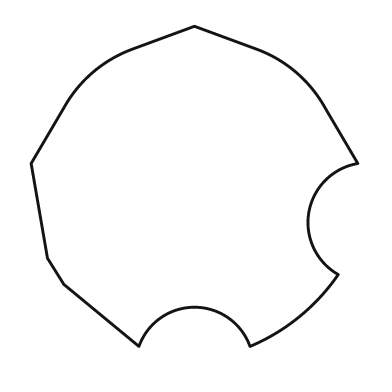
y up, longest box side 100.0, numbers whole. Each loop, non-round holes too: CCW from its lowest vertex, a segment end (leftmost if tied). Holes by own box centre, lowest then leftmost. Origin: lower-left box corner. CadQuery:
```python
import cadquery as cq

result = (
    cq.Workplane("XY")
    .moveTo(33.0, 0.0)
    .threePointArc((50.0, 12.0), (67.0, 0.0))
    .threePointArc((82.0, 9.0), (94.0, 22.0))
    .threePointArc((85.0, 41.0), (100.0, 56.0))
    .lineTo(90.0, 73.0)
    .threePointArc((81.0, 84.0), (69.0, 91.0))
    .lineTo(50.0, 98.0)
    .lineTo(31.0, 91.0)
    .threePointArc((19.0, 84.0), (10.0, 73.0))
    .lineTo(0.0, 56.0)
    .lineTo(5.0, 27.0)
    .lineTo(10.0, 19.0)
    .close()
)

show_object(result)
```